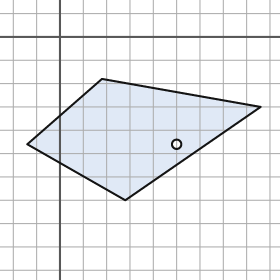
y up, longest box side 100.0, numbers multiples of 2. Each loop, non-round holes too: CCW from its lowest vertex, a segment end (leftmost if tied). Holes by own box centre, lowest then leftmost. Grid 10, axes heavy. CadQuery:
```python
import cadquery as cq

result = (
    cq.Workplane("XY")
    .moveTo(28.0, -70.0)
    .lineTo(86.0, -30.0)
    .lineTo(18.0, -18.0)
    .lineTo(-14.0, -46.0)
    .close()
    .moveTo(50.0, -46.0)
    .circle(2.0)
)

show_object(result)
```